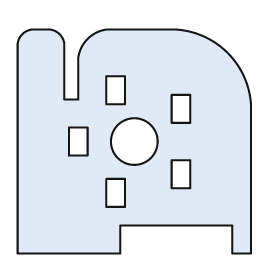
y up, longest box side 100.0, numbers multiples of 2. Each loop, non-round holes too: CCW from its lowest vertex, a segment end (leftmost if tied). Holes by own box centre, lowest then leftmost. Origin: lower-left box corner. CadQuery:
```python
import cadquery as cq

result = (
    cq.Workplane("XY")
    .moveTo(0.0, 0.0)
    .lineTo(44.0, 0.0)
    .lineTo(44.0, 12.0)
    .lineTo(92.0, 12.0)
    .lineTo(92.0, 0.0)
    .lineTo(100.0, 0.0)
    .lineTo(100.0, 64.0)
    .threePointArc((90.0, 86.0), (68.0, 96.0))
    .lineTo(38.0, 96.0)
    .threePointArc((30.0, 92.0), (26.0, 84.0))
    .lineTo(26.0, 66.0)
    .lineTo(20.0, 66.0)
    .lineTo(20.0, 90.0)
    .threePointArc((18.0, 94.0), (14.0, 96.0))
    .lineTo(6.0, 96.0)
    .threePointArc((2.0, 94.0), (0.0, 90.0))
    .close()
    .moveTo(38.0, 20.0)
    .lineTo(46.0, 20.0)
    .lineTo(46.0, 32.0)
    .lineTo(38.0, 32.0)
    .close()
    .moveTo(66.0, 28.0)
    .lineTo(74.0, 28.0)
    .lineTo(74.0, 40.0)
    .lineTo(66.0, 40.0)
    .close()
    .moveTo(22.0, 42.0)
    .lineTo(30.0, 42.0)
    .lineTo(30.0, 54.0)
    .lineTo(22.0, 54.0)
    .close()
    .moveTo(50.0, 48.0)
    .circle(10.0)
    .moveTo(66.0, 56.0)
    .lineTo(74.0, 56.0)
    .lineTo(74.0, 68.0)
    .lineTo(66.0, 68.0)
    .close()
    .moveTo(38.0, 64.0)
    .lineTo(46.0, 64.0)
    .lineTo(46.0, 76.0)
    .lineTo(38.0, 76.0)
    .close()
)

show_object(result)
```